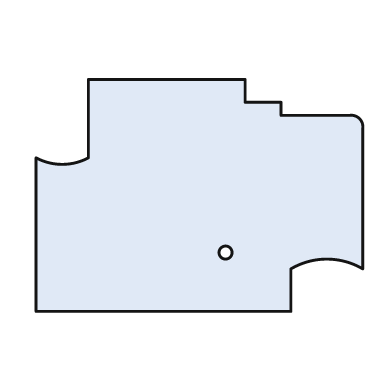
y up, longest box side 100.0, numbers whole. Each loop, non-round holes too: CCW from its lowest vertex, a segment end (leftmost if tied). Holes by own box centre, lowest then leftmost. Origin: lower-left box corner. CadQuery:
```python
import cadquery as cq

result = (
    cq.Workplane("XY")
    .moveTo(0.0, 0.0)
    .lineTo(78.0, 0.0)
    .lineTo(78.0, 13.0)
    .threePointArc((89.0, 16.0), (100.0, 13.0))
    .lineTo(100.0, 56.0)
    .threePointArc((99.0, 59.0), (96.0, 60.0))
    .lineTo(75.0, 60.0)
    .lineTo(75.0, 64.0)
    .lineTo(64.0, 64.0)
    .lineTo(64.0, 71.0)
    .lineTo(16.0, 71.0)
    .lineTo(16.0, 47.0)
    .threePointArc((8.0, 45.0), (0.0, 47.0))
    .close()
    .moveTo(58.0, 18.0)
    .circle(2.0)
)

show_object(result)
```